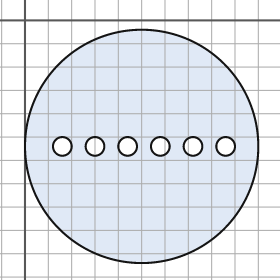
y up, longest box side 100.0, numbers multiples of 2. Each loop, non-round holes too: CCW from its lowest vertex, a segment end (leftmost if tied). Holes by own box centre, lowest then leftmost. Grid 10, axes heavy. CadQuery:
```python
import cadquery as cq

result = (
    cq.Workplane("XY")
    .moveTo(50.0, -54.0)
    .circle(50.0)
    .moveTo(16.0, -54.0)
    .circle(4.0)
    .moveTo(30.0, -54.0)
    .circle(4.0)
    .moveTo(44.0, -54.0)
    .circle(4.0)
    .moveTo(58.0, -54.0)
    .circle(4.0)
    .moveTo(72.0, -54.0)
    .circle(4.0)
    .moveTo(86.0, -54.0)
    .circle(4.0)
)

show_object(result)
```